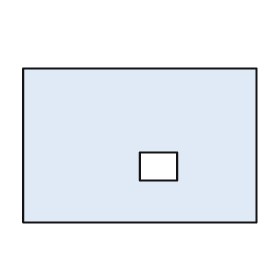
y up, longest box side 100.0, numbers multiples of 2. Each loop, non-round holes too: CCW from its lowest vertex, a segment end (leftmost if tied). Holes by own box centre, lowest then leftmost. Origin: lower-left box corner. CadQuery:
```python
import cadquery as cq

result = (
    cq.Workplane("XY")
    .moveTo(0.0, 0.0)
    .lineTo(100.0, 0.0)
    .lineTo(100.0, 66.0)
    .lineTo(0.0, 66.0)
    .close()
    .moveTo(50.0, 18.0)
    .lineTo(66.0, 18.0)
    .lineTo(66.0, 30.0)
    .lineTo(50.0, 30.0)
    .close()
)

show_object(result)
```